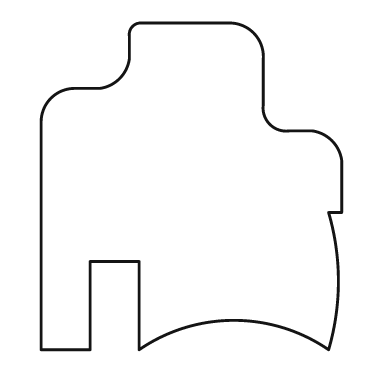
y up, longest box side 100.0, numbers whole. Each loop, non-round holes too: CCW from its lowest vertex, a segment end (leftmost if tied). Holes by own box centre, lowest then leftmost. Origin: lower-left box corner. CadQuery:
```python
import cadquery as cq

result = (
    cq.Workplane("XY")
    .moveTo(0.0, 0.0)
    .lineTo(15.0, 0.0)
    .lineTo(15.0, 27.0)
    .lineTo(30.0, 27.0)
    .lineTo(30.0, 0.0)
    .threePointArc((59.0, 9.0), (88.0, 0.0))
    .threePointArc((91.0, 21.0), (88.0, 42.0))
    .lineTo(92.0, 42.0)
    .lineTo(92.0, 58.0)
    .threePointArc((89.0, 64.0), (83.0, 67.0))
    .lineTo(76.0, 67.0)
    .threePointArc((70.0, 69.0), (68.0, 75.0))
    .lineTo(68.0, 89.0)
    .threePointArc((65.0, 97.0), (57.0, 100.0))
    .lineTo(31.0, 100.0)
    .threePointArc((28.0, 99.0), (27.0, 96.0))
    .lineTo(27.0, 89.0)
    .threePointArc((24.0, 83.0), (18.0, 80.0))
    .lineTo(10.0, 80.0)
    .threePointArc((3.0, 77.0), (0.0, 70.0))
    .close()
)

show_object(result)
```